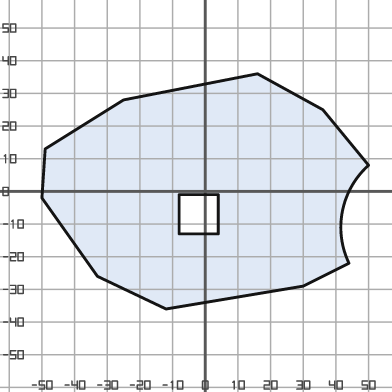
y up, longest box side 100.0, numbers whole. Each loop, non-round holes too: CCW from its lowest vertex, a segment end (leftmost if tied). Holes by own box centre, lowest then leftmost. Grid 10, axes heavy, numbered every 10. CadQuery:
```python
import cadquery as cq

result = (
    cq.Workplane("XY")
    .moveTo(-12.0, -36.0)
    .lineTo(30.0, -29.0)
    .lineTo(44.0, -22.0)
    .threePointArc((42.0, -6.0), (50.0, 8.0))
    .lineTo(36.0, 25.0)
    .lineTo(16.0, 36.0)
    .lineTo(-25.0, 28.0)
    .lineTo(-49.0, 13.0)
    .lineTo(-50.0, -2.0)
    .lineTo(-33.0, -26.0)
    .close()
    .moveTo(-8.0, -13.0)
    .lineTo(4.0, -13.0)
    .lineTo(4.0, -1.0)
    .lineTo(-8.0, -1.0)
    .close()
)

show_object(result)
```